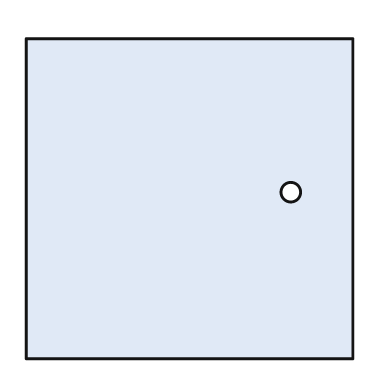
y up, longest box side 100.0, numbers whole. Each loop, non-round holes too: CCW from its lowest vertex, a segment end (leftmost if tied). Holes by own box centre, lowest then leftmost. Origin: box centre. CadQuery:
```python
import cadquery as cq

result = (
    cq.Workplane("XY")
    .moveTo(-50.0, -49.0)
    .lineTo(50.0, -49.0)
    .lineTo(50.0, 49.0)
    .lineTo(-50.0, 49.0)
    .close()
    .moveTo(31.0, 2.0)
    .circle(3.0)
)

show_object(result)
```